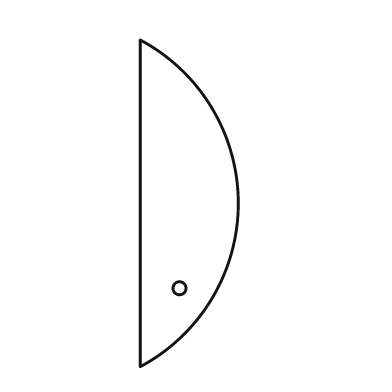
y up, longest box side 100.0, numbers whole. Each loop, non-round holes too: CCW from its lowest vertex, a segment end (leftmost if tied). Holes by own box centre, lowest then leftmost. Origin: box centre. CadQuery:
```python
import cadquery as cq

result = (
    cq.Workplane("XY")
    .moveTo(-15.0, -50.0)
    .threePointArc((15.0, 0.0), (-15.0, 50.0))
    .close()
    .moveTo(-3.0, -26.0)
    .circle(2.0)
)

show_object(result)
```